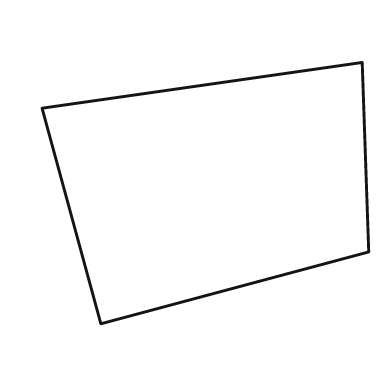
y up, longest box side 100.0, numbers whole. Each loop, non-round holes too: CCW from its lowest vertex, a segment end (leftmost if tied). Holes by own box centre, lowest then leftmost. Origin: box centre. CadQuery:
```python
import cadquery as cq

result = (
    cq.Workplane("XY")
    .moveTo(-32.0, -40.0)
    .lineTo(50.0, -18.0)
    .lineTo(48.0, 40.0)
    .lineTo(-50.0, 26.0)
    .close()
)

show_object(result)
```